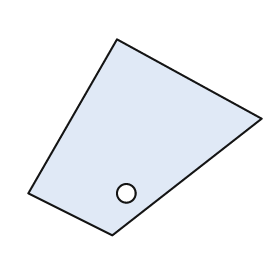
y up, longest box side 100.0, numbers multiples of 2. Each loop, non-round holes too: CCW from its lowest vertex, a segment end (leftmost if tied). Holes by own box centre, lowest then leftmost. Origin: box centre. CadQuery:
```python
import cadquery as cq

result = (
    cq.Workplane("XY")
    .moveTo(-14.0, -42.0)
    .lineTo(50.0, 8.0)
    .lineTo(-12.0, 42.0)
    .lineTo(-50.0, -24.0)
    .close()
    .moveTo(-8.0, -24.0)
    .circle(4.0)
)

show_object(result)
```